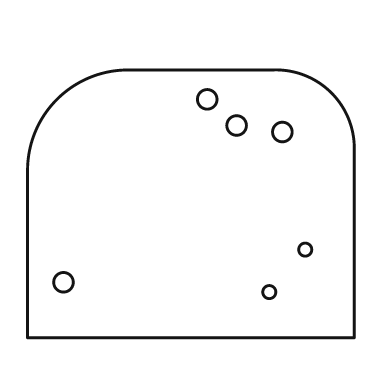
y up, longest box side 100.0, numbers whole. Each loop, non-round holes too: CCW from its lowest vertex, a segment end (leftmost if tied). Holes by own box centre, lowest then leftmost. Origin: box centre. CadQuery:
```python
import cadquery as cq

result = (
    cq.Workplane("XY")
    .moveTo(-50.0, -41.0)
    .lineTo(50.0, -41.0)
    .lineTo(50.0, 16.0)
    .threePointArc((43.0, 34.0), (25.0, 41.0))
    .lineTo(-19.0, 41.0)
    .threePointArc((-41.0, 32.0), (-50.0, 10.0))
    .close()
    .moveTo(24.0, -27.0)
    .circle(2.0)
    .moveTo(-39.0, -24.0)
    .circle(3.0)
    .moveTo(35.0, -14.0)
    .circle(2.0)
    .moveTo(28.0, 22.0)
    .circle(3.0)
    .moveTo(14.0, 24.0)
    .circle(3.0)
    .moveTo(5.0, 32.0)
    .circle(3.0)
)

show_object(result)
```